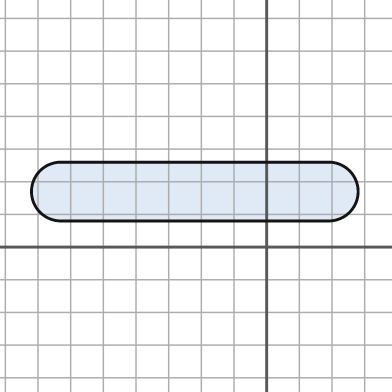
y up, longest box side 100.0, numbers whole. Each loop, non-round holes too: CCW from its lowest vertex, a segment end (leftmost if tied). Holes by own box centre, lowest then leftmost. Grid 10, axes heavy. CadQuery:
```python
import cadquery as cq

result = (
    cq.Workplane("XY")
    .moveTo(-63.0, 8.0)
    .lineTo(19.0, 8.0)
    .threePointArc((28.0, 17.0), (19.0, 26.0))
    .lineTo(-63.0, 26.0)
    .threePointArc((-72.0, 17.0), (-63.0, 8.0))
    .close()
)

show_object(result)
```